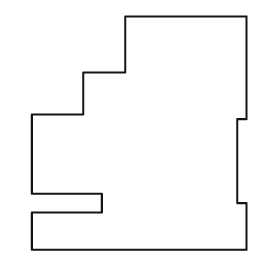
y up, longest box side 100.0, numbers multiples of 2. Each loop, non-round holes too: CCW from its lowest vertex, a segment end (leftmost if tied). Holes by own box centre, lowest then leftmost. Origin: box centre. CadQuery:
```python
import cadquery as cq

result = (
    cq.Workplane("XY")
    .moveTo(-46.0, -50.0)
    .lineTo(46.0, -50.0)
    .lineTo(46.0, -30.0)
    .lineTo(42.0, -30.0)
    .lineTo(42.0, 6.0)
    .lineTo(46.0, 6.0)
    .lineTo(46.0, 50.0)
    .lineTo(-6.0, 50.0)
    .lineTo(-6.0, 26.0)
    .lineTo(-24.0, 26.0)
    .lineTo(-24.0, 8.0)
    .lineTo(-46.0, 8.0)
    .lineTo(-46.0, -26.0)
    .lineTo(-16.0, -26.0)
    .lineTo(-16.0, -34.0)
    .lineTo(-46.0, -34.0)
    .close()
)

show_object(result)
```